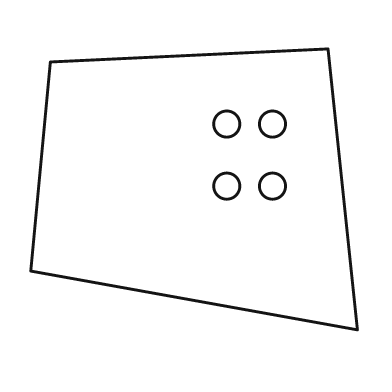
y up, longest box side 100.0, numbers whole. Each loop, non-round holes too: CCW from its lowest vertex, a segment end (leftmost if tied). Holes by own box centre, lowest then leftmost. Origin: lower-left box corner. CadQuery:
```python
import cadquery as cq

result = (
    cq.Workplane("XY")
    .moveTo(100.0, 0.0)
    .lineTo(91.0, 86.0)
    .lineTo(6.0, 82.0)
    .lineTo(0.0, 18.0)
    .close()
    .moveTo(60.0, 44.0)
    .circle(4.0)
    .moveTo(74.0, 44.0)
    .circle(4.0)
    .moveTo(60.0, 63.0)
    .circle(4.0)
    .moveTo(74.0, 63.0)
    .circle(4.0)
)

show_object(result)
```